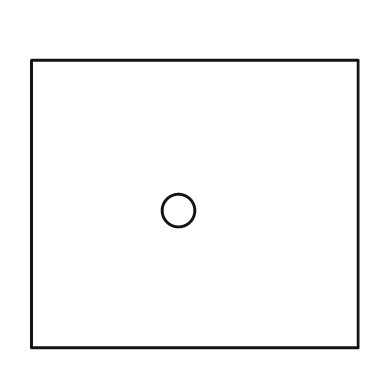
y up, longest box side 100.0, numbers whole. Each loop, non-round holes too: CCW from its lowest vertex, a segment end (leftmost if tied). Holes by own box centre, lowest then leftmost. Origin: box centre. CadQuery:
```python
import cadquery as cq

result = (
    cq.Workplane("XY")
    .moveTo(-50.0, -44.0)
    .lineTo(50.0, -44.0)
    .lineTo(50.0, 44.0)
    .lineTo(-50.0, 44.0)
    .close()
    .moveTo(-5.0, -2.0)
    .circle(5.0)
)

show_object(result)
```